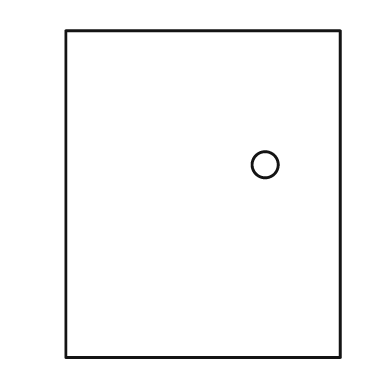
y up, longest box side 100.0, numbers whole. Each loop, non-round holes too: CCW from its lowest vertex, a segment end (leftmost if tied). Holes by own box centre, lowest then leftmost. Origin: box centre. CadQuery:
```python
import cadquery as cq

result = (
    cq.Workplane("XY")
    .moveTo(-42.0, -50.0)
    .lineTo(42.0, -50.0)
    .lineTo(42.0, 50.0)
    .lineTo(-42.0, 50.0)
    .close()
    .moveTo(19.0, 9.0)
    .circle(4.0)
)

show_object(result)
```